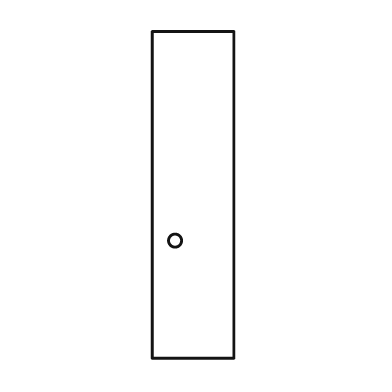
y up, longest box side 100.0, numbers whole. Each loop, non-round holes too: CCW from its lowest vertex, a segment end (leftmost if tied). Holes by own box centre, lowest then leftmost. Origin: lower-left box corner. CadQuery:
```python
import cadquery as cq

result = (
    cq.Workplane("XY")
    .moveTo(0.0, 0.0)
    .lineTo(25.0, 0.0)
    .lineTo(25.0, 100.0)
    .lineTo(0.0, 100.0)
    .close()
    .moveTo(7.0, 36.0)
    .circle(2.0)
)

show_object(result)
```